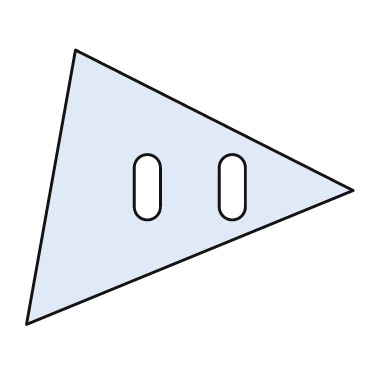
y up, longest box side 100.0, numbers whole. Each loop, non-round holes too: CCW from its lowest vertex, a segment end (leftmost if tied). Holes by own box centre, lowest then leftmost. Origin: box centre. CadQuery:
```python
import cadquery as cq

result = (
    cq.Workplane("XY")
    .moveTo(-50.0, -42.0)
    .lineTo(50.0, -1.0)
    .lineTo(-35.0, 42.0)
    .close()
    .moveTo(-17.0, -6.0)
    .threePointArc((-13.0, -10.0), (-9.0, -6.0))
    .lineTo(-9.0, 6.0)
    .threePointArc((-13.0, 10.0), (-17.0, 6.0))
    .close()
    .moveTo(9.0, -6.0)
    .threePointArc((13.0, -10.0), (17.0, -6.0))
    .lineTo(17.0, 6.0)
    .threePointArc((13.0, 10.0), (9.0, 6.0))
    .close()
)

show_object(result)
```